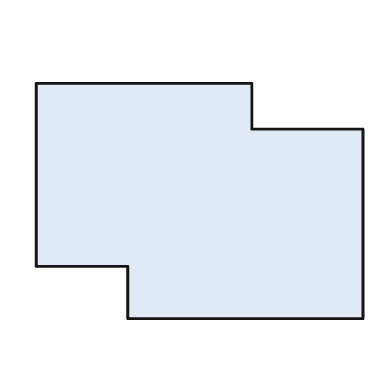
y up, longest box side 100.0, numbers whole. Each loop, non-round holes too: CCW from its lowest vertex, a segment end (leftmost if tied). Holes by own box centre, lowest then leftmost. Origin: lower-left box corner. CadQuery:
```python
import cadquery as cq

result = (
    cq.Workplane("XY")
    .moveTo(28.0, 0.0)
    .lineTo(100.0, 0.0)
    .lineTo(100.0, 58.0)
    .lineTo(66.0, 58.0)
    .lineTo(66.0, 72.0)
    .lineTo(0.0, 72.0)
    .lineTo(0.0, 16.0)
    .lineTo(28.0, 16.0)
    .close()
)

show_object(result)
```